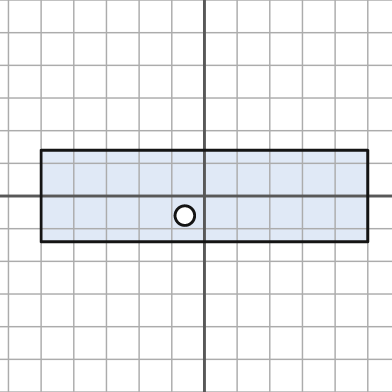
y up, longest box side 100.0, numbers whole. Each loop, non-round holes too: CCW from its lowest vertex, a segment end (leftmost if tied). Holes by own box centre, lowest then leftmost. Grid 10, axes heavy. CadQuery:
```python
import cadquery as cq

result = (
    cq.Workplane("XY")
    .moveTo(-50.0, -14.0)
    .lineTo(50.0, -14.0)
    .lineTo(50.0, 14.0)
    .lineTo(-50.0, 14.0)
    .close()
    .moveTo(-6.0, -6.0)
    .circle(3.0)
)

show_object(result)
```